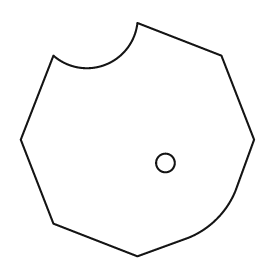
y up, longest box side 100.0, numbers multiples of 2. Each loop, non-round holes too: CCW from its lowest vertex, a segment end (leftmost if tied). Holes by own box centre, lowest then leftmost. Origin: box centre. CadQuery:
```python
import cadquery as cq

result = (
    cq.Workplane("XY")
    .moveTo(0.0, -50.0)
    .lineTo(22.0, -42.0)
    .threePointArc((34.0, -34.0), (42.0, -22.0))
    .lineTo(50.0, 0.0)
    .lineTo(36.0, 36.0)
    .lineTo(0.0, 50.0)
    .threePointArc((-14.0, 32.0), (-36.0, 36.0))
    .lineTo(-50.0, 0.0)
    .lineTo(-36.0, -36.0)
    .close()
    .moveTo(12.0, -10.0)
    .circle(4.0)
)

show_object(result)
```